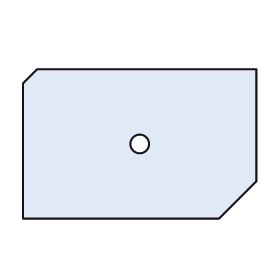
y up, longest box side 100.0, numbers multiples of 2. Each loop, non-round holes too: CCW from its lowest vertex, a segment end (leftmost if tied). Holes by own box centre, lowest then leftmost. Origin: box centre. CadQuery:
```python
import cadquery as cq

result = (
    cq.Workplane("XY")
    .moveTo(-50.0, -32.0)
    .lineTo(34.0, -32.0)
    .lineTo(50.0, -16.0)
    .lineTo(50.0, 32.0)
    .lineTo(-44.0, 32.0)
    .lineTo(-50.0, 26.0)
    .close()
    .moveTo(0.0, 0.0)
    .circle(4.0)
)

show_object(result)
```